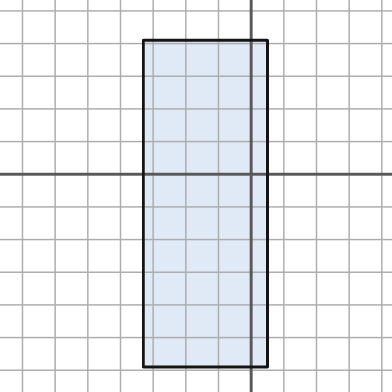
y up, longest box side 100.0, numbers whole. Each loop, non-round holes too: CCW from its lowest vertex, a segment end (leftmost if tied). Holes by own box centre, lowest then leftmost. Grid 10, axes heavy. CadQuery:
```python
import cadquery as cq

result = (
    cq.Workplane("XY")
    .moveTo(-33.0, -59.0)
    .lineTo(5.0, -59.0)
    .lineTo(5.0, 41.0)
    .lineTo(-33.0, 41.0)
    .close()
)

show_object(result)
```